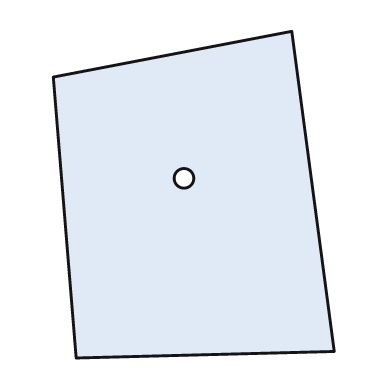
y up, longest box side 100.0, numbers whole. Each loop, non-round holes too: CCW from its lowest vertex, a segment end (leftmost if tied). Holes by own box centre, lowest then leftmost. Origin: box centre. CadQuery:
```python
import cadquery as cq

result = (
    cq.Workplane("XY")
    .moveTo(-36.0, -50.0)
    .lineTo(43.0, -48.0)
    .lineTo(30.0, 50.0)
    .lineTo(-43.0, 36.0)
    .close()
    .moveTo(-3.0, 5.0)
    .circle(3.0)
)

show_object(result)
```